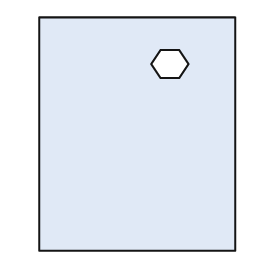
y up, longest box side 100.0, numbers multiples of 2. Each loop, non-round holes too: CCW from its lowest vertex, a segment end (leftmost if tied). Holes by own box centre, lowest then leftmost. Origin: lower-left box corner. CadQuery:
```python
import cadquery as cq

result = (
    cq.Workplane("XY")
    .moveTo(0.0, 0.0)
    .lineTo(84.0, 0.0)
    .lineTo(84.0, 100.0)
    .lineTo(0.0, 100.0)
    .close()
    .moveTo(52.0, 74.0)
    .lineTo(60.0, 74.0)
    .lineTo(64.0, 80.0)
    .lineTo(60.0, 86.0)
    .lineTo(52.0, 86.0)
    .lineTo(48.0, 80.0)
    .close()
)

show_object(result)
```